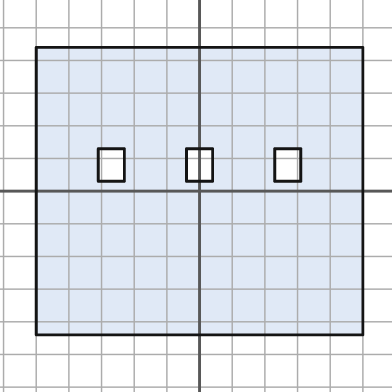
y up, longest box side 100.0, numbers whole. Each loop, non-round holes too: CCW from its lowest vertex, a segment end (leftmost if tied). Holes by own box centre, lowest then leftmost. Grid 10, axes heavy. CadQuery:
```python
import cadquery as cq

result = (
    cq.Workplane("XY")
    .moveTo(-50.0, -44.0)
    .lineTo(50.0, -44.0)
    .lineTo(50.0, 44.0)
    .lineTo(-50.0, 44.0)
    .close()
    .moveTo(-31.0, 3.0)
    .lineTo(-23.0, 3.0)
    .lineTo(-23.0, 13.0)
    .lineTo(-31.0, 13.0)
    .close()
    .moveTo(-4.0, 3.0)
    .lineTo(4.0, 3.0)
    .lineTo(4.0, 13.0)
    .lineTo(-4.0, 13.0)
    .close()
    .moveTo(23.0, 3.0)
    .lineTo(31.0, 3.0)
    .lineTo(31.0, 13.0)
    .lineTo(23.0, 13.0)
    .close()
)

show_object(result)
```